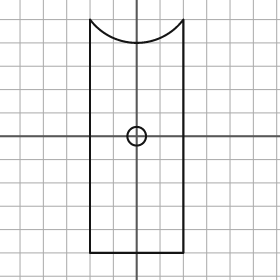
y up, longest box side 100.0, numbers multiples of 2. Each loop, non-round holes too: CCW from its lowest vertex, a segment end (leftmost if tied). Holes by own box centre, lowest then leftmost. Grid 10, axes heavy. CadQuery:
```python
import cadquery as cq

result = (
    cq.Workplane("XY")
    .moveTo(-20.0, -50.0)
    .lineTo(20.0, -50.0)
    .lineTo(20.0, 50.0)
    .threePointArc((0.0, 40.0), (-20.0, 50.0))
    .close()
    .moveTo(0.0, 0.0)
    .circle(4.0)
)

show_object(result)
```